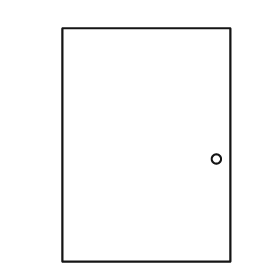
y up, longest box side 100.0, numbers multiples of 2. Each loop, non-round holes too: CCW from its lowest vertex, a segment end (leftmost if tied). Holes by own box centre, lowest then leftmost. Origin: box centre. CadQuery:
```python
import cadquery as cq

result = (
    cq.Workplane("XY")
    .moveTo(-36.0, -50.0)
    .lineTo(36.0, -50.0)
    .lineTo(36.0, 50.0)
    .lineTo(-36.0, 50.0)
    .close()
    .moveTo(30.0, -6.0)
    .circle(2.0)
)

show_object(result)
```